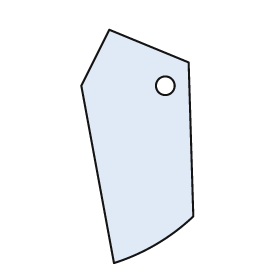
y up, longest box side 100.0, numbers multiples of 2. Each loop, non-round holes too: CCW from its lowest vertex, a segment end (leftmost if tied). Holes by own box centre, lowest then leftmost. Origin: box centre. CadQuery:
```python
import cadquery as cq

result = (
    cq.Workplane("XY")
    .moveTo(-10.0, -50.0)
    .threePointArc((8.0, -42.0), (24.0, -30.0))
    .lineTo(22.0, 36.0)
    .lineTo(-12.0, 50.0)
    .lineTo(-24.0, 26.0)
    .close()
    .moveTo(12.0, 26.0)
    .circle(4.0)
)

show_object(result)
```